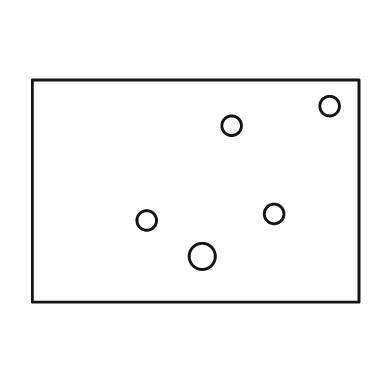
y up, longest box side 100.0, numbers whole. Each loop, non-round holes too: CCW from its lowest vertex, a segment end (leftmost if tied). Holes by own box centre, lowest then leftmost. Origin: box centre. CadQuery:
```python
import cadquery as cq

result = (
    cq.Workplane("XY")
    .moveTo(-50.0, -34.0)
    .lineTo(50.0, -34.0)
    .lineTo(50.0, 34.0)
    .lineTo(-50.0, 34.0)
    .close()
    .moveTo(2.0, -20.0)
    .circle(4.0)
    .moveTo(-15.0, -9.0)
    .circle(3.0)
    .moveTo(24.0, -7.0)
    .circle(3.0)
    .moveTo(11.0, 20.0)
    .circle(3.0)
    .moveTo(41.0, 26.0)
    .circle(3.0)
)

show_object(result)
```